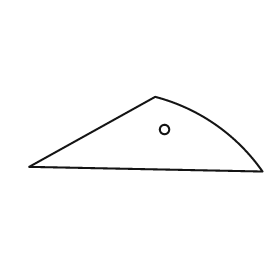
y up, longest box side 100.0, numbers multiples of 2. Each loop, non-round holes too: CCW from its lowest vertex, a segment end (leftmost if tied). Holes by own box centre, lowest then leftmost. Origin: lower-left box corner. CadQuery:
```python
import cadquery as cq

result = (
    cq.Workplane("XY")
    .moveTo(100.0, 0.0)
    .threePointArc((80.0, 20.0), (54.0, 32.0))
    .lineTo(0.0, 2.0)
    .close()
    .moveTo(58.0, 18.0)
    .circle(2.0)
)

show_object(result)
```